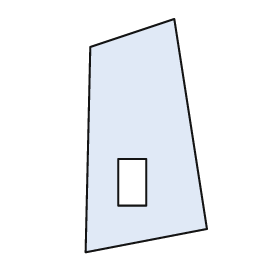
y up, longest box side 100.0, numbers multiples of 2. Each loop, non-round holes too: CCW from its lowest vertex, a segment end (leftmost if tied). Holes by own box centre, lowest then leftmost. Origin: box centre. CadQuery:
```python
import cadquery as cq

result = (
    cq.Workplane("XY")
    .moveTo(-26.0, -50.0)
    .lineTo(26.0, -40.0)
    .lineTo(12.0, 50.0)
    .lineTo(-24.0, 38.0)
    .close()
    .moveTo(-12.0, -30.0)
    .lineTo(0.0, -30.0)
    .lineTo(0.0, -10.0)
    .lineTo(-12.0, -10.0)
    .close()
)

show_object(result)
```